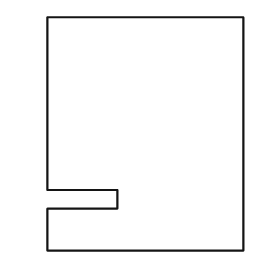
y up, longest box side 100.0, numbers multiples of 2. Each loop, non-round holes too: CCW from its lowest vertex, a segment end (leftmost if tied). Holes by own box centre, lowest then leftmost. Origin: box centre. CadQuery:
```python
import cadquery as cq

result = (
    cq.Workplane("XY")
    .moveTo(-42.0, -50.0)
    .lineTo(42.0, -50.0)
    .lineTo(42.0, 50.0)
    .lineTo(-42.0, 50.0)
    .lineTo(-42.0, -24.0)
    .lineTo(-12.0, -24.0)
    .lineTo(-12.0, -32.0)
    .lineTo(-42.0, -32.0)
    .close()
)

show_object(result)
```